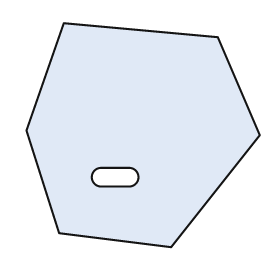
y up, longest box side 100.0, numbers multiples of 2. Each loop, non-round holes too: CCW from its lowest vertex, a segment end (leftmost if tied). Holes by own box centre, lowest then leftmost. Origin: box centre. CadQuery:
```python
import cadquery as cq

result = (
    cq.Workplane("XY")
    .moveTo(12.0, -48.0)
    .lineTo(50.0, 0.0)
    .lineTo(32.0, 42.0)
    .lineTo(-34.0, 48.0)
    .lineTo(-50.0, 2.0)
    .lineTo(-36.0, -42.0)
    .close()
    .moveTo(-18.0, -22.0)
    .lineTo(-6.0, -22.0)
    .threePointArc((-2.0, -18.0), (-6.0, -14.0))
    .lineTo(-18.0, -14.0)
    .threePointArc((-22.0, -18.0), (-18.0, -22.0))
    .close()
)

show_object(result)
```